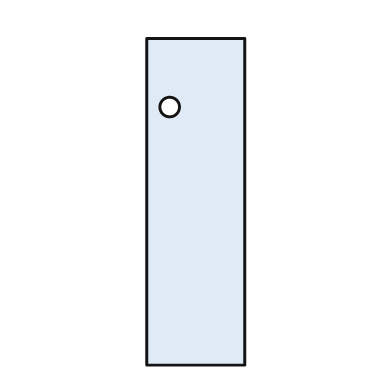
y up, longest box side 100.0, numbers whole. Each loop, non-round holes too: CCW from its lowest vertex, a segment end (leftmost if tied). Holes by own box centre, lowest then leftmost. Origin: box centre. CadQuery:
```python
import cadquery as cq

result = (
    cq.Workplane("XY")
    .moveTo(-15.0, -50.0)
    .lineTo(15.0, -50.0)
    .lineTo(15.0, 50.0)
    .lineTo(-15.0, 50.0)
    .close()
    .moveTo(-8.0, 29.0)
    .circle(3.0)
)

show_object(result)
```